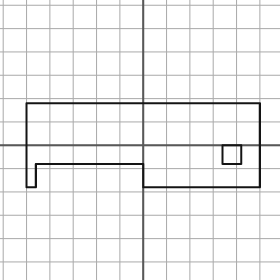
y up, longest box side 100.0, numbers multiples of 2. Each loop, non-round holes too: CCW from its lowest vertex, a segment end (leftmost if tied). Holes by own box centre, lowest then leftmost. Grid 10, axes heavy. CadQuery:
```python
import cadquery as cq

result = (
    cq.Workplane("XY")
    .moveTo(-50.0, -18.0)
    .lineTo(-46.0, -18.0)
    .lineTo(-46.0, -8.0)
    .lineTo(0.0, -8.0)
    .lineTo(0.0, -18.0)
    .lineTo(50.0, -18.0)
    .lineTo(50.0, 18.0)
    .lineTo(-50.0, 18.0)
    .close()
    .moveTo(34.0, -8.0)
    .lineTo(42.0, -8.0)
    .lineTo(42.0, 0.0)
    .lineTo(34.0, 0.0)
    .close()
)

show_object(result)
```